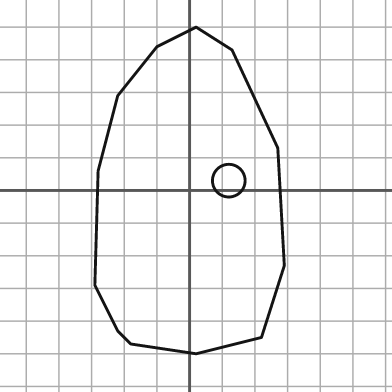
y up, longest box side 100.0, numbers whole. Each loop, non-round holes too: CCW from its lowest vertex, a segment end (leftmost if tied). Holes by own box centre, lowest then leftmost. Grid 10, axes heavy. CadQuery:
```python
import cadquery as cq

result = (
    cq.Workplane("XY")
    .moveTo(2.0, -50.0)
    .lineTo(22.0, -45.0)
    .lineTo(29.0, -23.0)
    .lineTo(27.0, 13.0)
    .lineTo(13.0, 43.0)
    .lineTo(2.0, 50.0)
    .lineTo(-10.0, 44.0)
    .lineTo(-22.0, 29.0)
    .lineTo(-28.0, 6.0)
    .lineTo(-29.0, -29.0)
    .lineTo(-22.0, -43.0)
    .lineTo(-18.0, -47.0)
    .close()
    .moveTo(12.0, 3.0)
    .circle(5.0)
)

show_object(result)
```